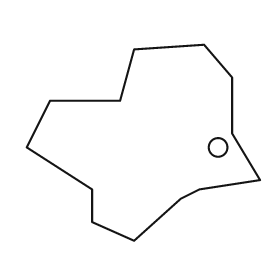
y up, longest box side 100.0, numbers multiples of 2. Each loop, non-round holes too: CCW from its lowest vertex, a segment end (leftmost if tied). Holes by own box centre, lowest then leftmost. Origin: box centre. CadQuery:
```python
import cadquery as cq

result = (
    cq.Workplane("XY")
    .moveTo(-4.0, -42.0)
    .lineTo(16.0, -24.0)
    .lineTo(24.0, -20.0)
    .lineTo(50.0, -16.0)
    .lineTo(38.0, 4.0)
    .lineTo(38.0, 28.0)
    .lineTo(26.0, 42.0)
    .lineTo(-4.0, 40.0)
    .lineTo(-10.0, 18.0)
    .lineTo(-40.0, 18.0)
    .lineTo(-50.0, -2.0)
    .lineTo(-22.0, -20.0)
    .lineTo(-22.0, -34.0)
    .close()
    .moveTo(32.0, -2.0)
    .circle(4.0)
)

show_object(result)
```